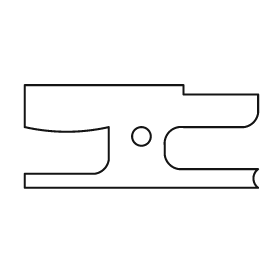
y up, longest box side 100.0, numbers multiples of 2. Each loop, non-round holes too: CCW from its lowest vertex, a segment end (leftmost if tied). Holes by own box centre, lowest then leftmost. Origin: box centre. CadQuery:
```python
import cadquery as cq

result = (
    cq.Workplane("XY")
    .moveTo(-50.0, -22.0)
    .lineTo(50.0, -22.0)
    .threePointArc((48.0, -18.0), (50.0, -14.0))
    .lineTo(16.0, -14.0)
    .threePointArc((12.0, -12.0), (10.0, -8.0))
    .lineTo(10.0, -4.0)
    .threePointArc((12.0, 2.0), (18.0, 4.0))
    .lineTo(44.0, 4.0)
    .threePointArc((48.0, 6.0), (50.0, 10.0))
    .lineTo(50.0, 18.0)
    .lineTo(18.0, 18.0)
    .lineTo(18.0, 22.0)
    .lineTo(-50.0, 22.0)
    .lineTo(-50.0, 4.0)
    .threePointArc((-32.0, 2.0), (-14.0, 4.0))
    .lineTo(-14.0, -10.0)
    .threePointArc((-16.0, -14.0), (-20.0, -16.0))
    .lineTo(-50.0, -16.0)
    .close()
    .moveTo(0.0, 0.0)
    .circle(4.0)
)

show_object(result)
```